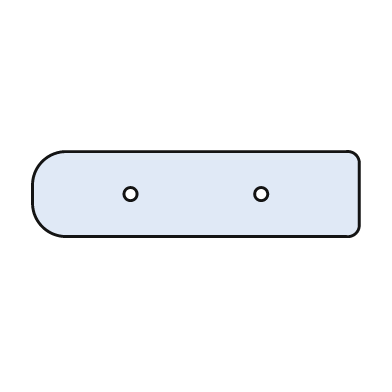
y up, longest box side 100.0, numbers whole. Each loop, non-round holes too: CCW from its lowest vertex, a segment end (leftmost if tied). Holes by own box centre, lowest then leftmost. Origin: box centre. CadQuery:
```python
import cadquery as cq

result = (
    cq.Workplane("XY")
    .moveTo(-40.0, -13.0)
    .lineTo(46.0, -13.0)
    .threePointArc((49.0, -12.0), (50.0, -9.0))
    .lineTo(50.0, 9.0)
    .threePointArc((49.0, 12.0), (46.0, 13.0))
    .lineTo(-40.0, 13.0)
    .threePointArc((-47.0, 10.0), (-50.0, 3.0))
    .lineTo(-50.0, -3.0)
    .threePointArc((-47.0, -10.0), (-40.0, -13.0))
    .close()
    .moveTo(-20.0, 0.0)
    .circle(2.0)
    .moveTo(20.0, 0.0)
    .circle(2.0)
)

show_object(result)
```